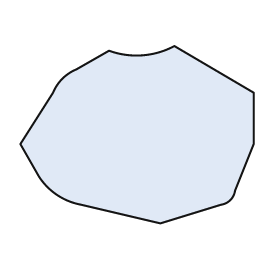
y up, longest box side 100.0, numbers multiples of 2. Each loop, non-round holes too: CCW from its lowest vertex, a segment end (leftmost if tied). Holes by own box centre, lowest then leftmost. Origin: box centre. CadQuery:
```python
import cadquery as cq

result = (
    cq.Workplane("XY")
    .moveTo(10.0, -38.0)
    .lineTo(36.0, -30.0)
    .threePointArc((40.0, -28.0), (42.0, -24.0))
    .lineTo(50.0, -4.0)
    .lineTo(50.0, 18.0)
    .lineTo(16.0, 38.0)
    .threePointArc((2.0, 34.0), (-12.0, 36.0))
    .lineTo(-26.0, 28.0)
    .threePointArc((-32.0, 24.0), (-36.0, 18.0))
    .lineTo(-50.0, -4.0)
    .lineTo(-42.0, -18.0)
    .threePointArc((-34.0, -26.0), (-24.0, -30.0))
    .close()
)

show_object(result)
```